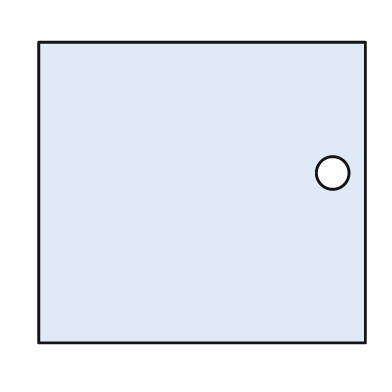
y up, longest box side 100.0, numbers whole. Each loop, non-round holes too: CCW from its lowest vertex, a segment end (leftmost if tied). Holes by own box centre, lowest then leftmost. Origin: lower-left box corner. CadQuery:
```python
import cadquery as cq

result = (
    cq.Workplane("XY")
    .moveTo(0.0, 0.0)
    .lineTo(100.0, 0.0)
    .lineTo(100.0, 92.0)
    .lineTo(0.0, 92.0)
    .close()
    .moveTo(90.0, 52.0)
    .circle(5.0)
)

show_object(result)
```